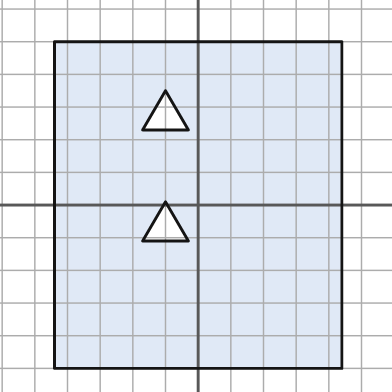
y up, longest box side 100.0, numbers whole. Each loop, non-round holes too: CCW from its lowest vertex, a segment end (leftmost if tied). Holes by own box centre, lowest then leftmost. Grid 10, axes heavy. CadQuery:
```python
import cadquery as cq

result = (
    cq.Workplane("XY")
    .moveTo(-44.0, -50.0)
    .lineTo(44.0, -50.0)
    .lineTo(44.0, 50.0)
    .lineTo(-44.0, 50.0)
    .close()
    .moveTo(-17.0, -11.0)
    .lineTo(-3.0, -11.0)
    .lineTo(-10.0, 1.0)
    .close()
    .moveTo(-17.0, 23.0)
    .lineTo(-3.0, 23.0)
    .lineTo(-10.0, 35.0)
    .close()
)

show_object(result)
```